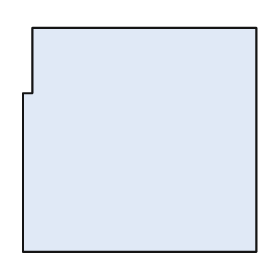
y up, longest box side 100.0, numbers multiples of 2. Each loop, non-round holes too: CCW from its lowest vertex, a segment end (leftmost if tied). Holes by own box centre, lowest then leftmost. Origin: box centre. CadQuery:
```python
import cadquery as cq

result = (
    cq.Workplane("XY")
    .moveTo(-50.0, -48.0)
    .lineTo(50.0, -48.0)
    .lineTo(50.0, 48.0)
    .lineTo(-46.0, 48.0)
    .lineTo(-46.0, 20.0)
    .lineTo(-50.0, 20.0)
    .close()
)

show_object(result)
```